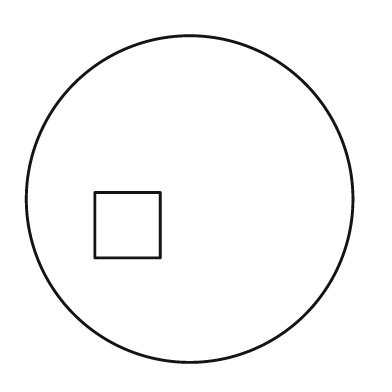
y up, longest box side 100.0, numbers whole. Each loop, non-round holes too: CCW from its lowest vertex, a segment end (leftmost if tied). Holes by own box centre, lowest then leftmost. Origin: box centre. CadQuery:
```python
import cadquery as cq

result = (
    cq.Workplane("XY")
    .moveTo(0.0, 0.0)
    .circle(50.0)
    .moveTo(-29.0, -18.0)
    .lineTo(-9.0, -18.0)
    .lineTo(-9.0, 2.0)
    .lineTo(-29.0, 2.0)
    .close()
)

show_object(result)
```